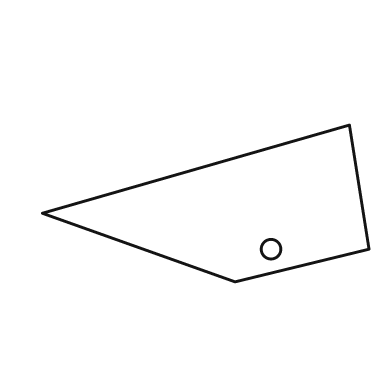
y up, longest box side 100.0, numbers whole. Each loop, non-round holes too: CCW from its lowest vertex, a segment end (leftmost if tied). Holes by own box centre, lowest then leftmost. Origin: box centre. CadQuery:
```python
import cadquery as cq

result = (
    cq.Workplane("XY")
    .moveTo(9.0, -24.0)
    .lineTo(50.0, -14.0)
    .lineTo(44.0, 24.0)
    .lineTo(-50.0, -3.0)
    .close()
    .moveTo(20.0, -14.0)
    .circle(3.0)
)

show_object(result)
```